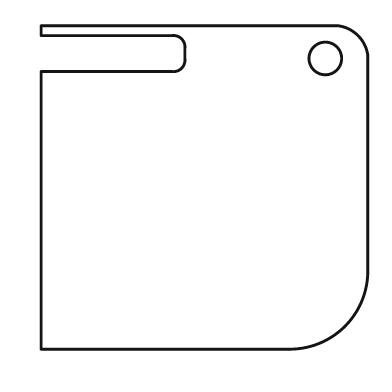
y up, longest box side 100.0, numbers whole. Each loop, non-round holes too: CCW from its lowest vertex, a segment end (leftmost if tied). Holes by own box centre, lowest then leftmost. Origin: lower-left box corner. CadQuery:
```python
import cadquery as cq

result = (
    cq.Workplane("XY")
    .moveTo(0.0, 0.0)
    .lineTo(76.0, 0.0)
    .threePointArc((93.0, 7.0), (100.0, 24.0))
    .lineTo(100.0, 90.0)
    .threePointArc((97.0, 96.0), (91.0, 99.0))
    .lineTo(0.0, 99.0)
    .lineTo(0.0, 96.0)
    .lineTo(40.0, 96.0)
    .threePointArc((43.0, 95.0), (44.0, 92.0))
    .lineTo(44.0, 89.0)
    .threePointArc((43.0, 86.0), (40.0, 85.0))
    .lineTo(0.0, 85.0)
    .close()
    .moveTo(87.0, 89.0)
    .circle(5.0)
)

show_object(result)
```